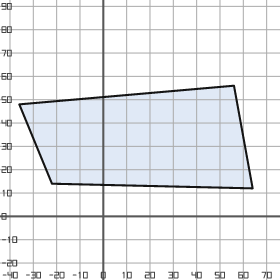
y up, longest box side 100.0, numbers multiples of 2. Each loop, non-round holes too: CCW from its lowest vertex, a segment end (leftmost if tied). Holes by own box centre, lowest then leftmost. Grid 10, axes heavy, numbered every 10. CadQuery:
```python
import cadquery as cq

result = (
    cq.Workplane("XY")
    .moveTo(64.0, 12.0)
    .lineTo(56.0, 56.0)
    .lineTo(-36.0, 48.0)
    .lineTo(-22.0, 14.0)
    .close()
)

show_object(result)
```